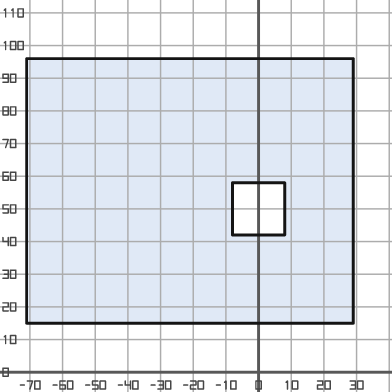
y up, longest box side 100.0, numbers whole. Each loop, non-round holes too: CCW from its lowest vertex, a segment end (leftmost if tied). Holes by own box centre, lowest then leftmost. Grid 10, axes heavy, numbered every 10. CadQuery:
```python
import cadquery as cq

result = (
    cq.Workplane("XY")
    .moveTo(-71.0, 15.0)
    .lineTo(29.0, 15.0)
    .lineTo(29.0, 96.0)
    .lineTo(-71.0, 96.0)
    .close()
    .moveTo(-8.0, 42.0)
    .lineTo(8.0, 42.0)
    .lineTo(8.0, 58.0)
    .lineTo(-8.0, 58.0)
    .close()
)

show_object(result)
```